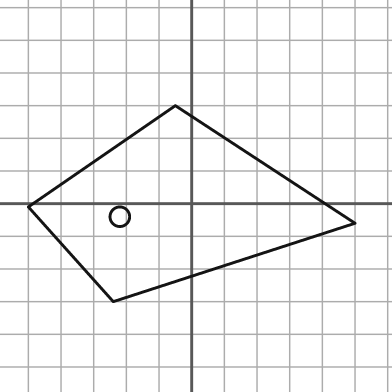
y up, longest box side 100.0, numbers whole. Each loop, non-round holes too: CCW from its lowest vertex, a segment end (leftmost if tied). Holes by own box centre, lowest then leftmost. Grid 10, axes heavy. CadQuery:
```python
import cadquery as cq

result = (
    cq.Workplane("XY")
    .moveTo(-24.0, -30.0)
    .lineTo(50.0, -6.0)
    .lineTo(-5.0, 30.0)
    .lineTo(-50.0, -1.0)
    .close()
    .moveTo(-22.0, -4.0)
    .circle(3.0)
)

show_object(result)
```